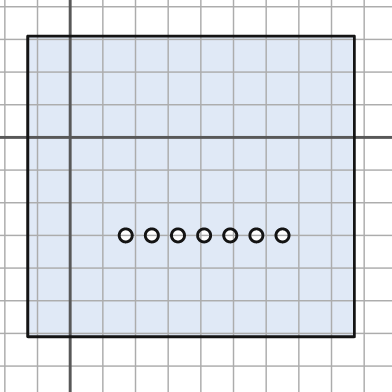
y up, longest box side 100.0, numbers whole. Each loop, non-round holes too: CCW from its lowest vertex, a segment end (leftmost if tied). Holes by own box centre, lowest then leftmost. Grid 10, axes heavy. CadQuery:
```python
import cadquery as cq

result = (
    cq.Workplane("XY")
    .moveTo(-13.0, -61.0)
    .lineTo(87.0, -61.0)
    .lineTo(87.0, 31.0)
    .lineTo(-13.0, 31.0)
    .close()
    .moveTo(17.0, -30.0)
    .circle(2.0)
    .moveTo(25.0, -30.0)
    .circle(2.0)
    .moveTo(33.0, -30.0)
    .circle(2.0)
    .moveTo(41.0, -30.0)
    .circle(2.0)
    .moveTo(49.0, -30.0)
    .circle(2.0)
    .moveTo(57.0, -30.0)
    .circle(2.0)
    .moveTo(65.0, -30.0)
    .circle(2.0)
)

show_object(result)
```